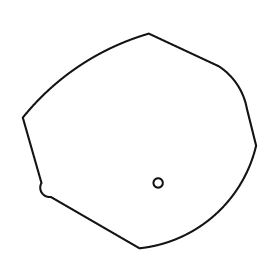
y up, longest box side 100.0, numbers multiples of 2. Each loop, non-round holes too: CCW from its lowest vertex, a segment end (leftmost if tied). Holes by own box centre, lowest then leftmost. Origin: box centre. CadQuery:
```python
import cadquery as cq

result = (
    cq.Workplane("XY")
    .moveTo(0.0, -46.0)
    .threePointArc((32.0, -32.0), (50.0, -2.0))
    .lineTo(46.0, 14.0)
    .threePointArc((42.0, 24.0), (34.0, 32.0))
    .lineTo(4.0, 46.0)
    .threePointArc((-26.0, 32.0), (-50.0, 10.0))
    .lineTo(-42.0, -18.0)
    .threePointArc((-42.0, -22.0), (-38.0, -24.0))
    .close()
    .moveTo(8.0, -18.0)
    .circle(2.0)
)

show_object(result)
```